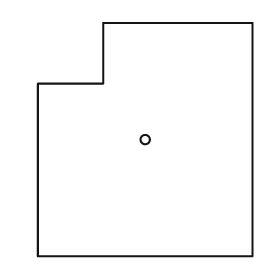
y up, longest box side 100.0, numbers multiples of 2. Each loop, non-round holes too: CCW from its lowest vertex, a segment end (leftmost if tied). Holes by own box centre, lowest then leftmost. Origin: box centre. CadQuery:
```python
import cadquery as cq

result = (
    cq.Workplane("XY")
    .moveTo(-46.0, -50.0)
    .lineTo(46.0, -50.0)
    .lineTo(46.0, 50.0)
    .lineTo(-18.0, 50.0)
    .lineTo(-18.0, 24.0)
    .lineTo(-46.0, 24.0)
    .close()
    .moveTo(0.0, 0.0)
    .circle(2.0)
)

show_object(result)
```